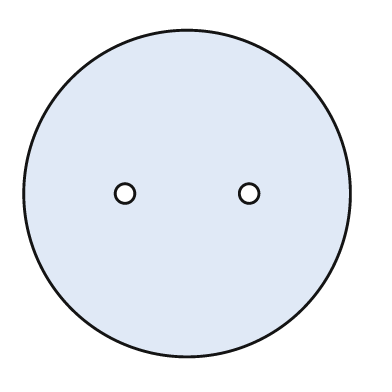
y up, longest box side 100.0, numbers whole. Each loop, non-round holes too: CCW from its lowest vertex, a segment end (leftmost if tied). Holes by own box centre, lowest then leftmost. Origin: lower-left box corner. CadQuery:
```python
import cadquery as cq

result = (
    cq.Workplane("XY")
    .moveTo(50.0, 50.0)
    .circle(50.0)
    .moveTo(31.0, 50.0)
    .circle(3.0)
    .moveTo(69.0, 50.0)
    .circle(3.0)
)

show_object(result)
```